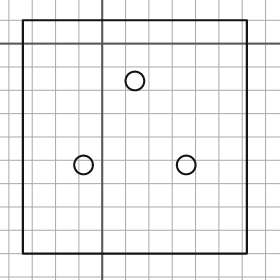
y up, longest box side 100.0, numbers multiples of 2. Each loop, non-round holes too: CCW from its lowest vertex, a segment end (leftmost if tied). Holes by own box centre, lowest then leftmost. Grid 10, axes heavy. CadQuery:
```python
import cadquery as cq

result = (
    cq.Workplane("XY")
    .moveTo(-34.0, -90.0)
    .lineTo(62.0, -90.0)
    .lineTo(62.0, 10.0)
    .lineTo(-34.0, 10.0)
    .close()
    .moveTo(-8.0, -52.0)
    .circle(4.0)
    .moveTo(36.0, -52.0)
    .circle(4.0)
    .moveTo(14.0, -16.0)
    .circle(4.0)
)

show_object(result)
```